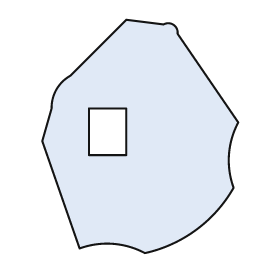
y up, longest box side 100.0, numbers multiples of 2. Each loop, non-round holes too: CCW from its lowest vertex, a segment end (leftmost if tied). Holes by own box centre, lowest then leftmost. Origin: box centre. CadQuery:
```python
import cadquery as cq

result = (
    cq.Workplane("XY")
    .moveTo(2.0, -50.0)
    .threePointArc((24.0, -40.0), (40.0, -22.0))
    .threePointArc((38.0, -8.0), (42.0, 6.0))
    .lineTo(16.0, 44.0)
    .threePointArc((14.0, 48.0), (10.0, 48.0))
    .lineTo(-6.0, 50.0)
    .lineTo(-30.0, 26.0)
    .threePointArc((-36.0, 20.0), (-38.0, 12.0))
    .lineTo(-42.0, -2.0)
    .lineTo(-26.0, -48.0)
    .threePointArc((-12.0, -46.0), (2.0, -50.0))
    .close()
    .moveTo(-22.0, -8.0)
    .lineTo(-6.0, -8.0)
    .lineTo(-6.0, 12.0)
    .lineTo(-22.0, 12.0)
    .close()
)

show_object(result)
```